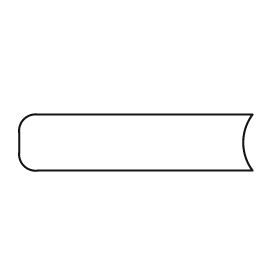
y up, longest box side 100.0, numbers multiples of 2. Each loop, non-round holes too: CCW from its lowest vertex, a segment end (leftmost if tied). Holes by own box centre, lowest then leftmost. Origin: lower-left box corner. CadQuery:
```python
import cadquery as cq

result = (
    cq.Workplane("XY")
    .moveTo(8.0, 0.0)
    .lineTo(100.0, 0.0)
    .threePointArc((96.0, 12.0), (100.0, 24.0))
    .lineTo(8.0, 24.0)
    .threePointArc((2.0, 22.0), (0.0, 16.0))
    .lineTo(0.0, 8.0)
    .threePointArc((2.0, 2.0), (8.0, 0.0))
    .close()
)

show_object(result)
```